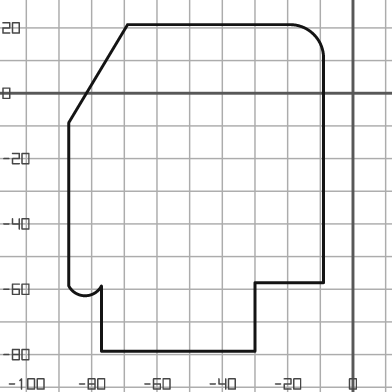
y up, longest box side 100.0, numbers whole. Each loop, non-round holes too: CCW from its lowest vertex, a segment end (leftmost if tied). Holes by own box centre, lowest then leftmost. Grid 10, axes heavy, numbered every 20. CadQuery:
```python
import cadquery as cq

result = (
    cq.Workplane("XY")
    .moveTo(-77.0, -79.0)
    .lineTo(-30.0, -79.0)
    .lineTo(-30.0, -58.0)
    .lineTo(-9.0, -58.0)
    .lineTo(-9.0, 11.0)
    .threePointArc((-12.0, 18.0), (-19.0, 21.0))
    .lineTo(-69.0, 21.0)
    .lineTo(-87.0, -9.0)
    .lineTo(-87.0, -59.0)
    .threePointArc((-82.0, -62.0), (-77.0, -59.0))
    .close()
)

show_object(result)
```